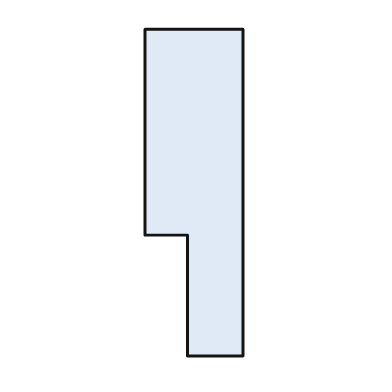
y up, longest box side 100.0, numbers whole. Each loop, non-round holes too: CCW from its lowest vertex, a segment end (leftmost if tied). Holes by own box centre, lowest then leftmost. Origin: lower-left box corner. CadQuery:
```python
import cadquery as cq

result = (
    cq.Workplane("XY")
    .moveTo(13.0, 0.0)
    .lineTo(30.0, 0.0)
    .lineTo(30.0, 100.0)
    .lineTo(0.0, 100.0)
    .lineTo(0.0, 37.0)
    .lineTo(13.0, 37.0)
    .close()
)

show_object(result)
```